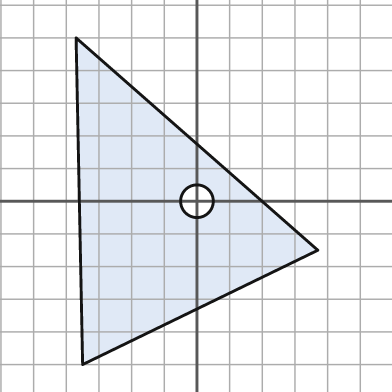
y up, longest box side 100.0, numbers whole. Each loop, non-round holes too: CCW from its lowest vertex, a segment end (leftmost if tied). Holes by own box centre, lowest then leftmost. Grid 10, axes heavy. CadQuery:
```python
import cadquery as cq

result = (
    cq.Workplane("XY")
    .moveTo(-35.0, -50.0)
    .lineTo(37.0, -15.0)
    .lineTo(-37.0, 50.0)
    .close()
    .moveTo(0.0, 0.0)
    .circle(5.0)
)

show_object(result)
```